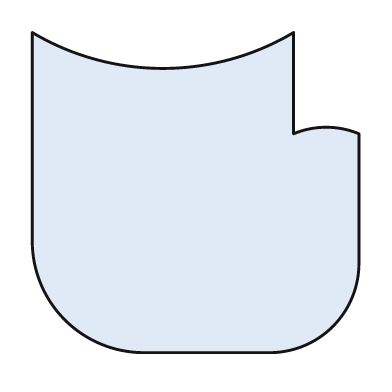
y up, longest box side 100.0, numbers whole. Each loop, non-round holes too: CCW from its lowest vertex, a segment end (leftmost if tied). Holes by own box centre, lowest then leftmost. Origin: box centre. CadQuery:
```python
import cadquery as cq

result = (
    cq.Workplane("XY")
    .moveTo(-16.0, -49.0)
    .lineTo(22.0, -49.0)
    .threePointArc((42.0, -41.0), (50.0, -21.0))
    .lineTo(50.0, 18.0)
    .threePointArc((40.0, 20.0), (30.0, 18.0))
    .lineTo(30.0, 49.0)
    .threePointArc((-10.0, 38.0), (-50.0, 49.0))
    .lineTo(-50.0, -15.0)
    .threePointArc((-40.0, -39.0), (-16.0, -49.0))
    .close()
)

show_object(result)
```